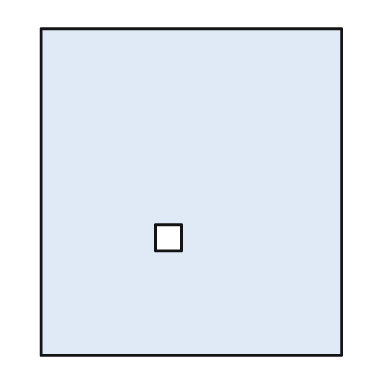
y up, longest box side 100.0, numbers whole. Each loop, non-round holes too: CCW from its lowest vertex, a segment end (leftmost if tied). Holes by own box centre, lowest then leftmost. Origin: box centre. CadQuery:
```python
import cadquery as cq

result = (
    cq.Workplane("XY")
    .moveTo(-46.0, -50.0)
    .lineTo(46.0, -50.0)
    .lineTo(46.0, 50.0)
    .lineTo(-46.0, 50.0)
    .close()
    .moveTo(-11.0, -18.0)
    .lineTo(-3.0, -18.0)
    .lineTo(-3.0, -10.0)
    .lineTo(-11.0, -10.0)
    .close()
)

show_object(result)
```